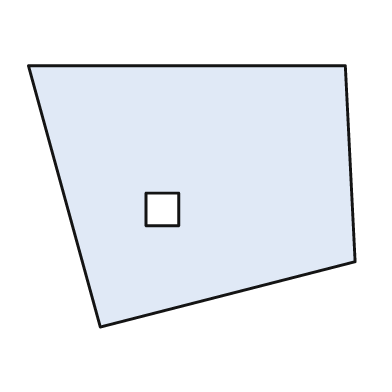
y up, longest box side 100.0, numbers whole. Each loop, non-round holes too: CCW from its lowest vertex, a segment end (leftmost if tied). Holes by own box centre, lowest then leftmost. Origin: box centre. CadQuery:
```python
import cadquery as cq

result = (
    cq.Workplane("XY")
    .moveTo(-28.0, -40.0)
    .lineTo(50.0, -20.0)
    .lineTo(47.0, 40.0)
    .lineTo(-50.0, 40.0)
    .close()
    .moveTo(-14.0, -9.0)
    .lineTo(-4.0, -9.0)
    .lineTo(-4.0, 1.0)
    .lineTo(-14.0, 1.0)
    .close()
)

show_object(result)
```